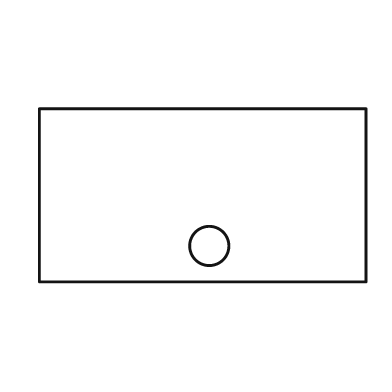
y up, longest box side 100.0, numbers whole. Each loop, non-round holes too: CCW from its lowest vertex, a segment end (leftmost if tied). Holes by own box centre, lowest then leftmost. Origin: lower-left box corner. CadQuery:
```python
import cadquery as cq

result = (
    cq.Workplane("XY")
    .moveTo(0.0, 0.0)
    .lineTo(100.0, 0.0)
    .lineTo(100.0, 53.0)
    .lineTo(0.0, 53.0)
    .close()
    .moveTo(52.0, 11.0)
    .circle(6.0)
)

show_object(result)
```